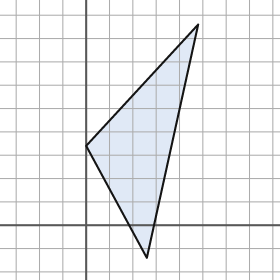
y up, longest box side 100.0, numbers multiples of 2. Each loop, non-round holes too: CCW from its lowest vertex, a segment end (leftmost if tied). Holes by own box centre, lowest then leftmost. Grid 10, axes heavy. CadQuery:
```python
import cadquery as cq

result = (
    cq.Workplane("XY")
    .moveTo(26.0, -14.0)
    .lineTo(48.0, 86.0)
    .lineTo(0.0, 34.0)
    .close()
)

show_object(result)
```